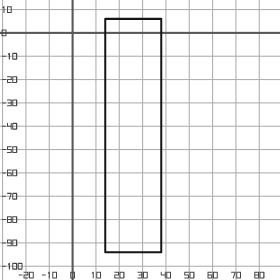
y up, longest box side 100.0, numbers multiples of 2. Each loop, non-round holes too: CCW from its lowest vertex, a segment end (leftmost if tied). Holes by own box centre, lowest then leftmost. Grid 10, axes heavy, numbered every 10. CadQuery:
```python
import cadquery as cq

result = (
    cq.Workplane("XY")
    .moveTo(14.0, -94.0)
    .lineTo(38.0, -94.0)
    .lineTo(38.0, 6.0)
    .lineTo(14.0, 6.0)
    .close()
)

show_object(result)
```